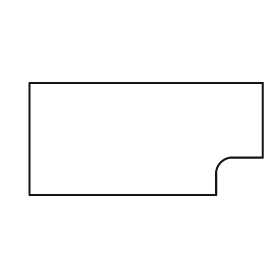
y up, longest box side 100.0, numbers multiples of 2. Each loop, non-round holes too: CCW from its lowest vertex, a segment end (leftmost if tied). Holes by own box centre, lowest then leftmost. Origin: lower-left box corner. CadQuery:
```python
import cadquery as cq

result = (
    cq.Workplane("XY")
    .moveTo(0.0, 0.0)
    .lineTo(80.0, 0.0)
    .lineTo(80.0, 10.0)
    .threePointArc((82.0, 14.0), (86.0, 16.0))
    .lineTo(100.0, 16.0)
    .lineTo(100.0, 48.0)
    .lineTo(0.0, 48.0)
    .close()
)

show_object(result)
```